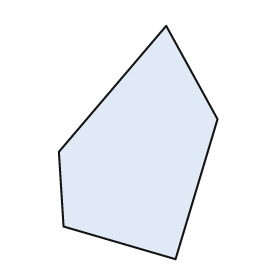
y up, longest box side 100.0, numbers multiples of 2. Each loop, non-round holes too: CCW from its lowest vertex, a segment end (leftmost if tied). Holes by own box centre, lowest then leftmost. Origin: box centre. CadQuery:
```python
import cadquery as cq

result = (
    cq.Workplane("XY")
    .moveTo(16.0, -50.0)
    .lineTo(34.0, 10.0)
    .lineTo(12.0, 50.0)
    .lineTo(-34.0, -4.0)
    .lineTo(-32.0, -36.0)
    .close()
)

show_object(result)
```